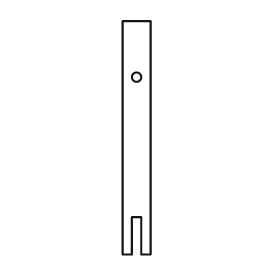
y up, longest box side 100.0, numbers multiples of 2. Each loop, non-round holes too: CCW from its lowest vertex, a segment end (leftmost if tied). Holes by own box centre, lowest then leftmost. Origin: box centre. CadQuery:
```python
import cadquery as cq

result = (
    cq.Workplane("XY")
    .moveTo(-6.0, -50.0)
    .lineTo(-2.0, -50.0)
    .lineTo(-2.0, -34.0)
    .lineTo(2.0, -34.0)
    .lineTo(2.0, -50.0)
    .lineTo(6.0, -50.0)
    .lineTo(6.0, 50.0)
    .lineTo(-6.0, 50.0)
    .close()
    .moveTo(0.0, 26.0)
    .circle(2.0)
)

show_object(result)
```